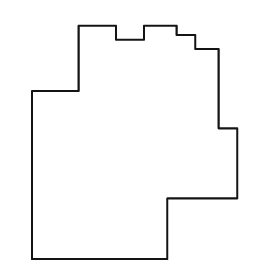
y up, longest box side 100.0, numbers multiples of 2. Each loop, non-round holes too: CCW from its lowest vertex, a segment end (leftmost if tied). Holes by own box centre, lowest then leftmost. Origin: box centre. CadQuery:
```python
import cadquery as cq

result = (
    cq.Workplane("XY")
    .moveTo(-44.0, -50.0)
    .lineTo(14.0, -50.0)
    .lineTo(14.0, -24.0)
    .lineTo(44.0, -24.0)
    .lineTo(44.0, 6.0)
    .lineTo(36.0, 6.0)
    .lineTo(36.0, 40.0)
    .lineTo(26.0, 40.0)
    .lineTo(26.0, 46.0)
    .lineTo(18.0, 46.0)
    .lineTo(18.0, 50.0)
    .lineTo(4.0, 50.0)
    .lineTo(4.0, 44.0)
    .lineTo(-8.0, 44.0)
    .lineTo(-8.0, 50.0)
    .lineTo(-24.0, 50.0)
    .lineTo(-24.0, 22.0)
    .lineTo(-44.0, 22.0)
    .close()
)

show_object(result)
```